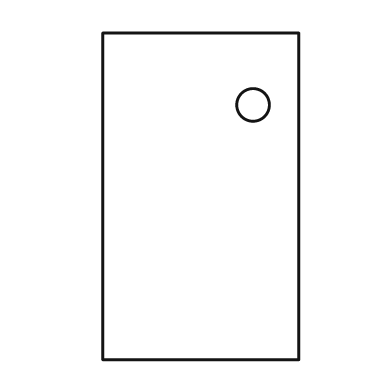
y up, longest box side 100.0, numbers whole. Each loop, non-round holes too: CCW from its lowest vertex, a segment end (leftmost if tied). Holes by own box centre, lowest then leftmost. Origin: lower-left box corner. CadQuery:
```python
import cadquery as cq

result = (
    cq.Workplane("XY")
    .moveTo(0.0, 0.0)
    .lineTo(60.0, 0.0)
    .lineTo(60.0, 100.0)
    .lineTo(0.0, 100.0)
    .close()
    .moveTo(46.0, 78.0)
    .circle(5.0)
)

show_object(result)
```